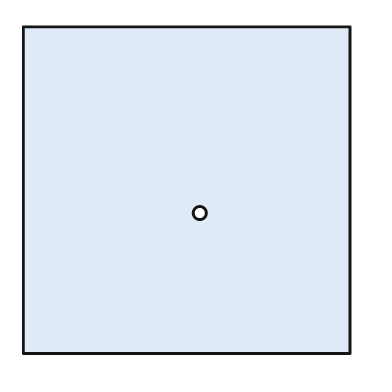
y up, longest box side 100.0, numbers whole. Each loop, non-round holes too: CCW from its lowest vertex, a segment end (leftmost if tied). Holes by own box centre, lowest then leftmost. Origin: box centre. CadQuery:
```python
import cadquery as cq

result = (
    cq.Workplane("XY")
    .moveTo(-50.0, -50.0)
    .lineTo(50.0, -50.0)
    .lineTo(50.0, 50.0)
    .lineTo(-50.0, 50.0)
    .close()
    .moveTo(4.0, -7.0)
    .circle(2.0)
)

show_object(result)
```